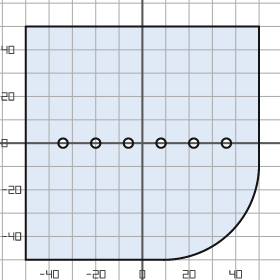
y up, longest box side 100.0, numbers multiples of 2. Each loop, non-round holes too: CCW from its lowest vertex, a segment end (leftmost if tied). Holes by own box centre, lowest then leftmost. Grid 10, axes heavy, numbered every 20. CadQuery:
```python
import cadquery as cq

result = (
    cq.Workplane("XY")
    .moveTo(-50.0, -50.0)
    .lineTo(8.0, -50.0)
    .threePointArc((38.0, -38.0), (50.0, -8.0))
    .lineTo(50.0, 50.0)
    .lineTo(-50.0, 50.0)
    .close()
    .moveTo(-34.0, 0.0)
    .circle(2.0)
    .moveTo(-20.0, 0.0)
    .circle(2.0)
    .moveTo(-6.0, 0.0)
    .circle(2.0)
    .moveTo(8.0, 0.0)
    .circle(2.0)
    .moveTo(22.0, 0.0)
    .circle(2.0)
    .moveTo(36.0, 0.0)
    .circle(2.0)
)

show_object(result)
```